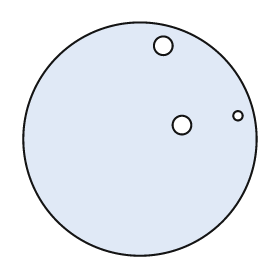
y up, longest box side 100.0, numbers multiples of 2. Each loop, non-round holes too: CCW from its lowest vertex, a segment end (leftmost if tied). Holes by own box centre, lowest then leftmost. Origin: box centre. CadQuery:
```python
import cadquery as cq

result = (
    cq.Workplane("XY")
    .moveTo(0.0, 0.0)
    .circle(50.0)
    .moveTo(18.0, 6.0)
    .circle(4.0)
    .moveTo(42.0, 10.0)
    .circle(2.0)
    .moveTo(10.0, 40.0)
    .circle(4.0)
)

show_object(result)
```